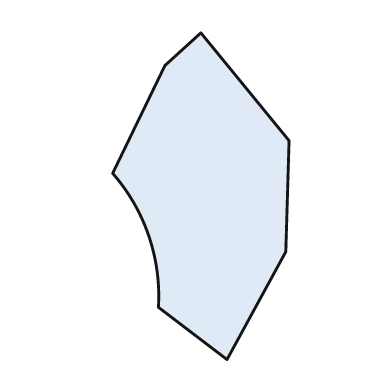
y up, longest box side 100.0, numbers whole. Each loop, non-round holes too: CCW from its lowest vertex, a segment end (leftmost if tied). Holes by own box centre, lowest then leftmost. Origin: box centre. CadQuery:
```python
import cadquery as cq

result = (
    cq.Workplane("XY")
    .moveTo(8.0, -50.0)
    .lineTo(26.0, -17.0)
    .lineTo(27.0, 17.0)
    .lineTo(0.0, 50.0)
    .lineTo(-11.0, 40.0)
    .lineTo(-27.0, 7.0)
    .threePointArc((-16.0, -12.0), (-13.0, -34.0))
    .close()
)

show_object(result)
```